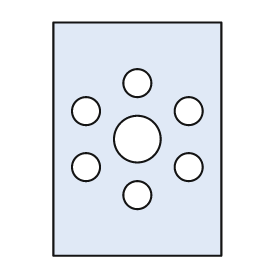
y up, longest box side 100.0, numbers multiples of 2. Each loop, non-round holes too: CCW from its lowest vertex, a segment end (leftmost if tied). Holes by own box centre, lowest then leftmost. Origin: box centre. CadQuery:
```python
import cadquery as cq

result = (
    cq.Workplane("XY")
    .moveTo(-36.0, -50.0)
    .lineTo(36.0, -50.0)
    .lineTo(36.0, 50.0)
    .lineTo(-36.0, 50.0)
    .close()
    .moveTo(0.0, -24.0)
    .circle(6.0)
    .moveTo(-22.0, -12.0)
    .circle(6.0)
    .moveTo(22.0, -12.0)
    .circle(6.0)
    .moveTo(0.0, 0.0)
    .circle(10.0)
    .moveTo(-22.0, 12.0)
    .circle(6.0)
    .moveTo(22.0, 12.0)
    .circle(6.0)
    .moveTo(0.0, 24.0)
    .circle(6.0)
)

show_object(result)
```